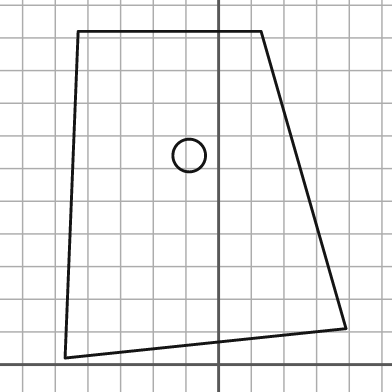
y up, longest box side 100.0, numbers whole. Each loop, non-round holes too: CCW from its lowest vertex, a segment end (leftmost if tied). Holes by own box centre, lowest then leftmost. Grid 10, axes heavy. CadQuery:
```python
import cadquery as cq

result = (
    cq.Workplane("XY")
    .moveTo(-47.0, 2.0)
    .lineTo(39.0, 11.0)
    .lineTo(13.0, 102.0)
    .lineTo(-43.0, 102.0)
    .close()
    .moveTo(-9.0, 64.0)
    .circle(5.0)
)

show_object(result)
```